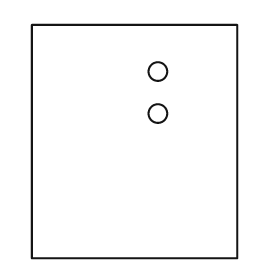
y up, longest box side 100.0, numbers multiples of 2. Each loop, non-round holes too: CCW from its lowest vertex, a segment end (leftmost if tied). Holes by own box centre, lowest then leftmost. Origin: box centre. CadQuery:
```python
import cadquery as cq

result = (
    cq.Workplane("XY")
    .moveTo(-44.0, -50.0)
    .lineTo(44.0, -50.0)
    .lineTo(44.0, 50.0)
    .lineTo(-44.0, 50.0)
    .close()
    .moveTo(10.0, 12.0)
    .circle(4.0)
    .moveTo(10.0, 30.0)
    .circle(4.0)
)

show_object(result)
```